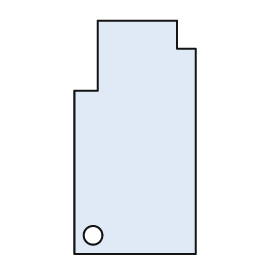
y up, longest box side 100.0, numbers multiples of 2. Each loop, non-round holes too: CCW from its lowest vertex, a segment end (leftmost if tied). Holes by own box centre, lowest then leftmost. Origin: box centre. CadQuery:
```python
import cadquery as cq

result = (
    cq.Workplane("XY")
    .moveTo(-26.0, -50.0)
    .lineTo(26.0, -50.0)
    .lineTo(26.0, 38.0)
    .lineTo(18.0, 38.0)
    .lineTo(18.0, 50.0)
    .lineTo(-16.0, 50.0)
    .lineTo(-16.0, 20.0)
    .lineTo(-26.0, 20.0)
    .close()
    .moveTo(-18.0, -42.0)
    .circle(4.0)
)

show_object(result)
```